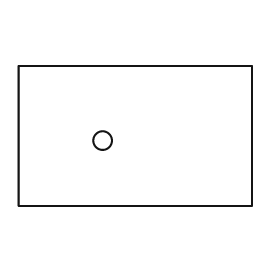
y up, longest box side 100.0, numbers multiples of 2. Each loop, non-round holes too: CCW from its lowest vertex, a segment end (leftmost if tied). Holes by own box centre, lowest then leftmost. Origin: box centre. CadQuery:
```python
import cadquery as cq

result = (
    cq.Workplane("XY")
    .moveTo(-50.0, -30.0)
    .lineTo(50.0, -30.0)
    .lineTo(50.0, 30.0)
    .lineTo(-50.0, 30.0)
    .close()
    .moveTo(-14.0, -2.0)
    .circle(4.0)
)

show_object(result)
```